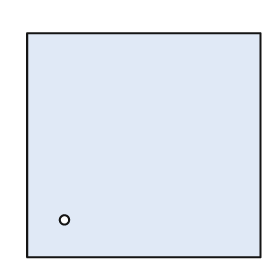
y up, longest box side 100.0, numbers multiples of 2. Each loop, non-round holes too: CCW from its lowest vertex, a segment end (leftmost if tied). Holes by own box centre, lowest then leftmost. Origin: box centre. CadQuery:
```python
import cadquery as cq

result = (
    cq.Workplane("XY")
    .moveTo(-50.0, -48.0)
    .lineTo(50.0, -48.0)
    .lineTo(50.0, 48.0)
    .lineTo(-50.0, 48.0)
    .close()
    .moveTo(-34.0, -32.0)
    .circle(2.0)
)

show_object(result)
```